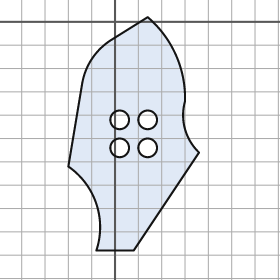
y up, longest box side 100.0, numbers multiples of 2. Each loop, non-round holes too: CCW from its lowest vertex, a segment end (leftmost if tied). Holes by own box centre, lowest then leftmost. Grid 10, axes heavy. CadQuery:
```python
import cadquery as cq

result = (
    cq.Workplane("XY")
    .moveTo(-8.0, -98.0)
    .lineTo(8.0, -98.0)
    .lineTo(36.0, -56.0)
    .threePointArc((30.0, -46.0), (30.0, -34.0))
    .threePointArc((26.0, -14.0), (14.0, 2.0))
    .lineTo(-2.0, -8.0)
    .threePointArc((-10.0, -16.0), (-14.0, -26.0))
    .lineTo(-20.0, -62.0)
    .threePointArc((-8.0, -78.0), (-8.0, -98.0))
    .close()
    .moveTo(2.0, -54.0)
    .circle(4.0)
    .moveTo(14.0, -54.0)
    .circle(4.0)
    .moveTo(2.0, -42.0)
    .circle(4.0)
    .moveTo(14.0, -42.0)
    .circle(4.0)
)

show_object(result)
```